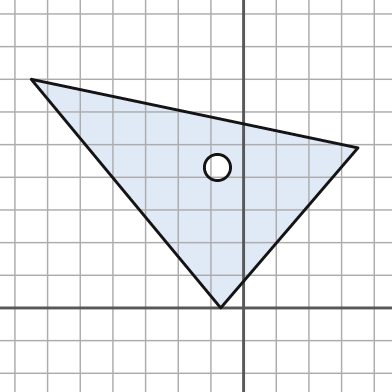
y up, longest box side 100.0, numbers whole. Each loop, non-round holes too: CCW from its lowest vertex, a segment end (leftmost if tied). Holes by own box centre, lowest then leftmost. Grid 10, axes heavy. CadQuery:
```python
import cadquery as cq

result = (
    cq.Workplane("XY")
    .moveTo(-7.0, 0.0)
    .lineTo(35.0, 49.0)
    .lineTo(-65.0, 70.0)
    .close()
    .moveTo(-8.0, 43.0)
    .circle(4.0)
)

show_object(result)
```